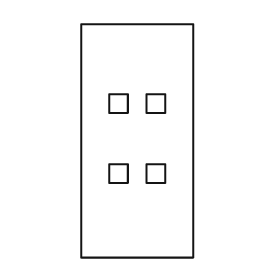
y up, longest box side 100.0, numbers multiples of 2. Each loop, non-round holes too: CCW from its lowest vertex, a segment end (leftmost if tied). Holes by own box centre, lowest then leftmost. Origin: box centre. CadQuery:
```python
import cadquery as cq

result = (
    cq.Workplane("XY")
    .moveTo(-24.0, -50.0)
    .lineTo(24.0, -50.0)
    .lineTo(24.0, 50.0)
    .lineTo(-24.0, 50.0)
    .close()
    .moveTo(-12.0, -18.0)
    .lineTo(-4.0, -18.0)
    .lineTo(-4.0, -10.0)
    .lineTo(-12.0, -10.0)
    .close()
    .moveTo(4.0, -18.0)
    .lineTo(12.0, -18.0)
    .lineTo(12.0, -10.0)
    .lineTo(4.0, -10.0)
    .close()
    .moveTo(-12.0, 12.0)
    .lineTo(-4.0, 12.0)
    .lineTo(-4.0, 20.0)
    .lineTo(-12.0, 20.0)
    .close()
    .moveTo(4.0, 12.0)
    .lineTo(12.0, 12.0)
    .lineTo(12.0, 20.0)
    .lineTo(4.0, 20.0)
    .close()
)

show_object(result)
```